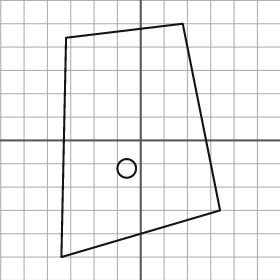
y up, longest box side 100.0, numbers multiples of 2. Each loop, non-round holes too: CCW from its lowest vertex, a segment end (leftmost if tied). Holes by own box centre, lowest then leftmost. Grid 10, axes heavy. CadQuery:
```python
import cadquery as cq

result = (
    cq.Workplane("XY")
    .moveTo(-34.0, -50.0)
    .lineTo(34.0, -30.0)
    .lineTo(18.0, 50.0)
    .lineTo(-32.0, 44.0)
    .close()
    .moveTo(-6.0, -12.0)
    .circle(4.0)
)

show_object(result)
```